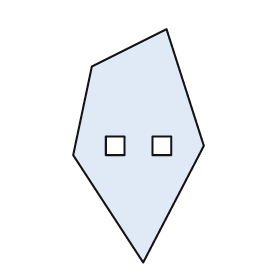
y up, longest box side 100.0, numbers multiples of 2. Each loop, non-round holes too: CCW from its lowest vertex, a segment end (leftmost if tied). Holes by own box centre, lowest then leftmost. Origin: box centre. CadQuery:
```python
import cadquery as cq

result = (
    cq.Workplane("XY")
    .moveTo(2.0, -50.0)
    .lineTo(28.0, 0.0)
    .lineTo(12.0, 50.0)
    .lineTo(-20.0, 34.0)
    .lineTo(-28.0, -4.0)
    .close()
    .moveTo(-14.0, -4.0)
    .lineTo(-6.0, -4.0)
    .lineTo(-6.0, 4.0)
    .lineTo(-14.0, 4.0)
    .close()
    .moveTo(6.0, -4.0)
    .lineTo(14.0, -4.0)
    .lineTo(14.0, 4.0)
    .lineTo(6.0, 4.0)
    .close()
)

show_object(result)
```